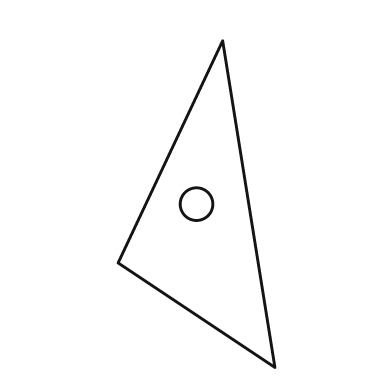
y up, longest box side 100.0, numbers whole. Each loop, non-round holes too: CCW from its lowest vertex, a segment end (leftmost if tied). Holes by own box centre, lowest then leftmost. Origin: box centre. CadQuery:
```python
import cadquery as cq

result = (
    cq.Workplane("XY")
    .moveTo(24.0, -50.0)
    .lineTo(8.0, 50.0)
    .lineTo(-24.0, -18.0)
    .close()
    .moveTo(0.0, 0.0)
    .circle(5.0)
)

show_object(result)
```